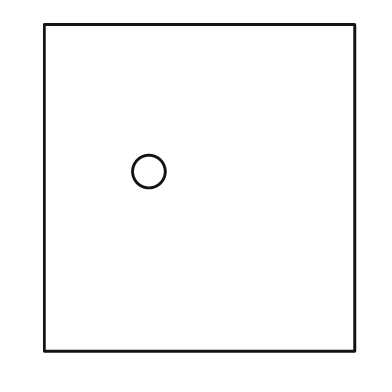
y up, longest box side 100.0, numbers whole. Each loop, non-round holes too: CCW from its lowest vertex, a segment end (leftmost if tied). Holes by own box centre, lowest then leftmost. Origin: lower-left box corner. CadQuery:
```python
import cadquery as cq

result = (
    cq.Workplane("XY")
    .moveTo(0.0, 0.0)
    .lineTo(95.0, 0.0)
    .lineTo(95.0, 100.0)
    .lineTo(0.0, 100.0)
    .close()
    .moveTo(32.0, 55.0)
    .circle(5.0)
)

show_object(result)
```